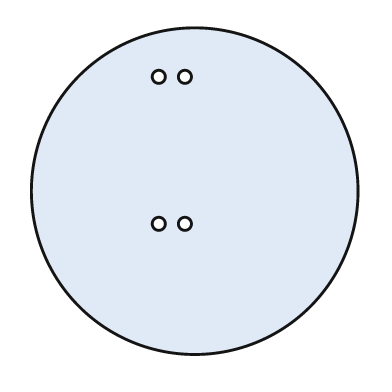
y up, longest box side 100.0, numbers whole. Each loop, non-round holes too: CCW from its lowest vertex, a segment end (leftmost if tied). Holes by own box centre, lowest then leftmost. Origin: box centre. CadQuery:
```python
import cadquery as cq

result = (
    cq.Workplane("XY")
    .moveTo(0.0, 0.0)
    .circle(50.0)
    .moveTo(-11.0, -10.0)
    .circle(2.0)
    .moveTo(-3.0, -10.0)
    .circle(2.0)
    .moveTo(-11.0, 35.0)
    .circle(2.0)
    .moveTo(-3.0, 35.0)
    .circle(2.0)
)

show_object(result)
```